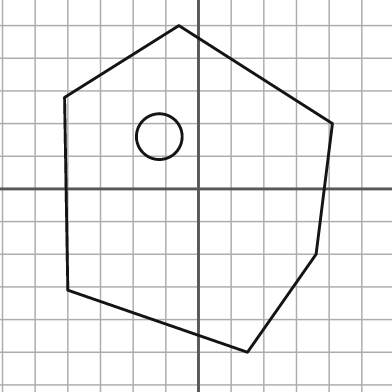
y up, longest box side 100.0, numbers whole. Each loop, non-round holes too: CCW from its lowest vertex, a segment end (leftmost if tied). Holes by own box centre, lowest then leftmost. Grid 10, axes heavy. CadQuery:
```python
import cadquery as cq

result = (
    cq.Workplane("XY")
    .moveTo(15.0, -50.0)
    .lineTo(36.0, -20.0)
    .lineTo(41.0, 20.0)
    .lineTo(-6.0, 50.0)
    .lineTo(-41.0, 28.0)
    .lineTo(-40.0, -31.0)
    .close()
    .moveTo(-12.0, 16.0)
    .circle(7.0)
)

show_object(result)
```